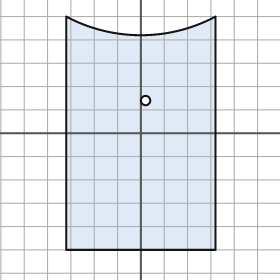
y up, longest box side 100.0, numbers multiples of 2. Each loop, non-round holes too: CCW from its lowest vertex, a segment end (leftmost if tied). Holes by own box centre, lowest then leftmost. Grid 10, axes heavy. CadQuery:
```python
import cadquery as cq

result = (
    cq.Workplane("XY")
    .moveTo(-32.0, -50.0)
    .lineTo(32.0, -50.0)
    .lineTo(32.0, 50.0)
    .threePointArc((0.0, 42.0), (-32.0, 50.0))
    .close()
    .moveTo(2.0, 14.0)
    .circle(2.0)
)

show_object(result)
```